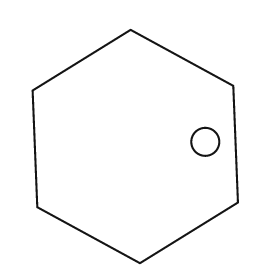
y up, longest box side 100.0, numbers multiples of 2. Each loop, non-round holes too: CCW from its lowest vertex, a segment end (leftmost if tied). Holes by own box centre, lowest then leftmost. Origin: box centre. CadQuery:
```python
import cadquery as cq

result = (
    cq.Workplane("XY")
    .moveTo(2.0, -50.0)
    .lineTo(44.0, -24.0)
    .lineTo(42.0, 26.0)
    .lineTo(-2.0, 50.0)
    .lineTo(-44.0, 24.0)
    .lineTo(-42.0, -26.0)
    .close()
    .moveTo(30.0, 2.0)
    .circle(6.0)
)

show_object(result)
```